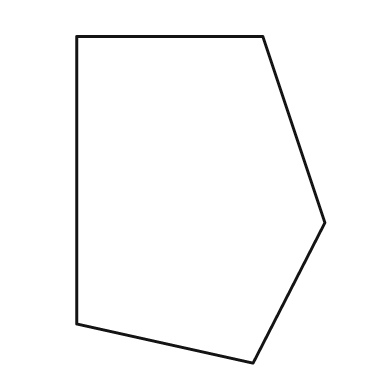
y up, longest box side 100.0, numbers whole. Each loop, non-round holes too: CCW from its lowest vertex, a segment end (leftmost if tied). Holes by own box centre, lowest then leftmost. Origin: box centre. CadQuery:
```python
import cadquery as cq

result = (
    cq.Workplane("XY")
    .moveTo(16.0, -50.0)
    .lineTo(38.0, -7.0)
    .lineTo(19.0, 50.0)
    .lineTo(-38.0, 50.0)
    .lineTo(-38.0, -38.0)
    .close()
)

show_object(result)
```